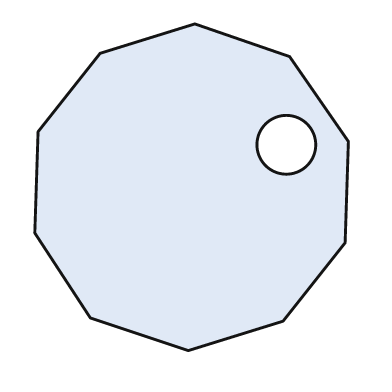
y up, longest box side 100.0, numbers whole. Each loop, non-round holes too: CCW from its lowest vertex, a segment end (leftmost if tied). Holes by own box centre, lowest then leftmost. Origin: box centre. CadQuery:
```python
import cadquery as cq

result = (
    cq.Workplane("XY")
    .moveTo(-1.0, -50.0)
    .lineTo(28.0, -41.0)
    .lineTo(47.0, -17.0)
    .lineTo(48.0, 14.0)
    .lineTo(30.0, 40.0)
    .lineTo(1.0, 50.0)
    .lineTo(-28.0, 41.0)
    .lineTo(-47.0, 17.0)
    .lineTo(-48.0, -14.0)
    .lineTo(-31.0, -40.0)
    .close()
    .moveTo(29.0, 13.0)
    .circle(9.0)
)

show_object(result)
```